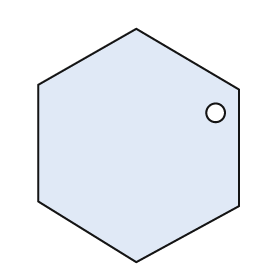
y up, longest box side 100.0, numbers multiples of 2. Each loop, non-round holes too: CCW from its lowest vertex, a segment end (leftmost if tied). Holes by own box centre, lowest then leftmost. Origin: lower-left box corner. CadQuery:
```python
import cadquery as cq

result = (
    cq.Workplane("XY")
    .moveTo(42.0, 0.0)
    .lineTo(86.0, 24.0)
    .lineTo(86.0, 74.0)
    .lineTo(42.0, 100.0)
    .lineTo(0.0, 76.0)
    .lineTo(0.0, 26.0)
    .close()
    .moveTo(76.0, 64.0)
    .circle(4.0)
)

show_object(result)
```